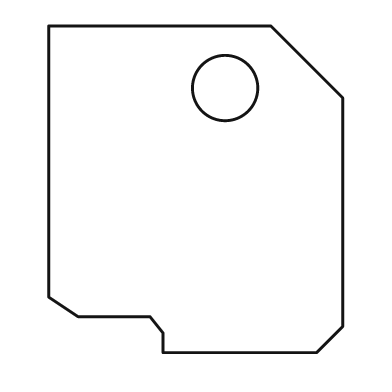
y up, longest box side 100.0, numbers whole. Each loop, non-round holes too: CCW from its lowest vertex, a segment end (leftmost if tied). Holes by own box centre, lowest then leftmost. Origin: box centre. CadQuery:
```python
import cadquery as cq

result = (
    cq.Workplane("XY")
    .moveTo(-10.0, -50.0)
    .lineTo(37.0, -50.0)
    .lineTo(45.0, -42.0)
    .lineTo(45.0, 28.0)
    .lineTo(23.0, 50.0)
    .lineTo(-45.0, 50.0)
    .lineTo(-45.0, -33.0)
    .lineTo(-36.0, -39.0)
    .lineTo(-14.0, -39.0)
    .lineTo(-10.0, -44.0)
    .close()
    .moveTo(9.0, 31.0)
    .circle(10.0)
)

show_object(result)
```